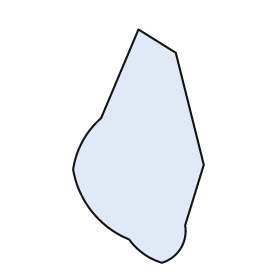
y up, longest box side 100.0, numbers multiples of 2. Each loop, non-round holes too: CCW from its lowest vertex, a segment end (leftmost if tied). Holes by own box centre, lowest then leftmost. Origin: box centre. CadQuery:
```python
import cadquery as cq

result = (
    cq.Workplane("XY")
    .moveTo(10.0, -50.0)
    .threePointArc((18.0, -44.0), (20.0, -34.0))
    .lineTo(28.0, -8.0)
    .lineTo(16.0, 40.0)
    .lineTo(0.0, 50.0)
    .lineTo(-16.0, 12.0)
    .threePointArc((-24.0, 2.0), (-28.0, -10.0))
    .threePointArc((-20.0, -28.0), (-4.0, -40.0))
    .threePointArc((2.0, -46.0), (10.0, -50.0))
    .close()
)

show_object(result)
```